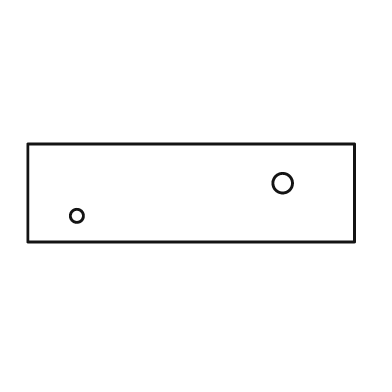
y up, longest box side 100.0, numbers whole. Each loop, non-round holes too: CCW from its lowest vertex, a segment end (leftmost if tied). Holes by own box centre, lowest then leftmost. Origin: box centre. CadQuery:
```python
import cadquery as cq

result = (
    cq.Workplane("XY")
    .moveTo(-50.0, -15.0)
    .lineTo(50.0, -15.0)
    .lineTo(50.0, 15.0)
    .lineTo(-50.0, 15.0)
    .close()
    .moveTo(-35.0, -7.0)
    .circle(2.0)
    .moveTo(28.0, 3.0)
    .circle(3.0)
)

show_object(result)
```